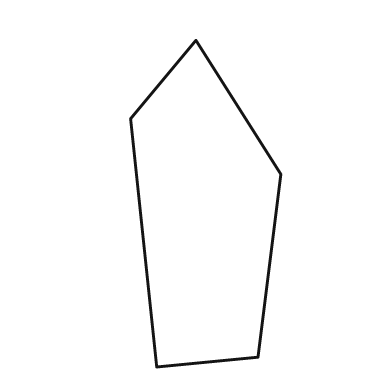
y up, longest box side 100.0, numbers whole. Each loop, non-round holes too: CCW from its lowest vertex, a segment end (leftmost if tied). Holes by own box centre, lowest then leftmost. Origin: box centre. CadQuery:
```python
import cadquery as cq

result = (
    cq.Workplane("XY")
    .moveTo(-15.0, -50.0)
    .lineTo(16.0, -47.0)
    .lineTo(23.0, 9.0)
    .lineTo(-3.0, 50.0)
    .lineTo(-23.0, 26.0)
    .close()
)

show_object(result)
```